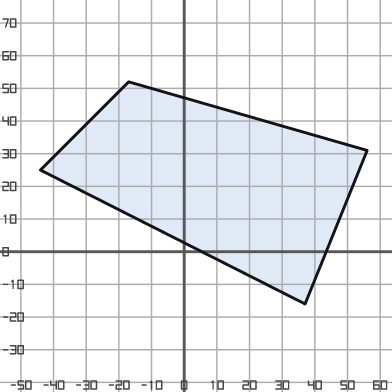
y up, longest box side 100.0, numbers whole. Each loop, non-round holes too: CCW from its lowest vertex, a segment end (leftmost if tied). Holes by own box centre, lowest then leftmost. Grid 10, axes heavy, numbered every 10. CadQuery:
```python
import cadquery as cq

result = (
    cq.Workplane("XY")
    .moveTo(37.0, -16.0)
    .lineTo(56.0, 31.0)
    .lineTo(-17.0, 52.0)
    .lineTo(-44.0, 25.0)
    .close()
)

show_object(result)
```